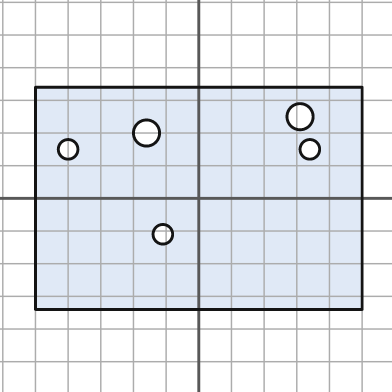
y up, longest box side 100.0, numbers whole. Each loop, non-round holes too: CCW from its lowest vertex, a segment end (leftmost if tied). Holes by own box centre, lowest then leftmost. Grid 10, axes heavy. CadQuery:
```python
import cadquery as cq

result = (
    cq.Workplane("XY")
    .moveTo(-50.0, -34.0)
    .lineTo(50.0, -34.0)
    .lineTo(50.0, 34.0)
    .lineTo(-50.0, 34.0)
    .close()
    .moveTo(-11.0, -11.0)
    .circle(3.0)
    .moveTo(-40.0, 15.0)
    .circle(3.0)
    .moveTo(34.0, 15.0)
    .circle(3.0)
    .moveTo(-16.0, 20.0)
    .circle(4.0)
    .moveTo(31.0, 25.0)
    .circle(4.0)
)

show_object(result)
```